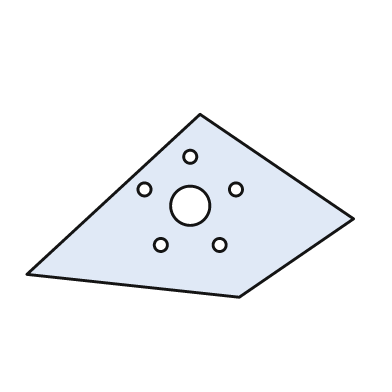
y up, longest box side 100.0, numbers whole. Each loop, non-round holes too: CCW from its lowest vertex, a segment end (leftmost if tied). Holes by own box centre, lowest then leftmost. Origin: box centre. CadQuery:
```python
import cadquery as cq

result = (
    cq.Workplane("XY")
    .moveTo(15.0, -28.0)
    .lineTo(50.0, -4.0)
    .lineTo(3.0, 28.0)
    .lineTo(-50.0, -21.0)
    .close()
    .moveTo(-9.0, -12.0)
    .circle(2.0)
    .moveTo(9.0, -12.0)
    .circle(2.0)
    .moveTo(0.0, 0.0)
    .circle(6.0)
    .moveTo(-14.0, 5.0)
    .circle(2.0)
    .moveTo(14.0, 5.0)
    .circle(2.0)
    .moveTo(0.0, 15.0)
    .circle(2.0)
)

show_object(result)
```